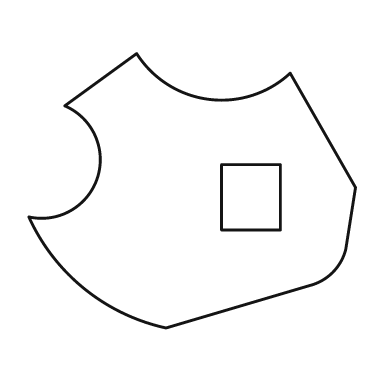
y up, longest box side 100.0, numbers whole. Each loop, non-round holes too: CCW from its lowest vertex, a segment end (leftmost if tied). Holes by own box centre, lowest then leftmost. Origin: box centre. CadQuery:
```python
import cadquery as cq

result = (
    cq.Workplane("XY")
    .moveTo(-8.0, -42.0)
    .lineTo(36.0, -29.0)
    .threePointArc((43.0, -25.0), (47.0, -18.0))
    .lineTo(50.0, 1.0)
    .lineTo(30.0, 36.0)
    .threePointArc((5.0, 28.0), (-17.0, 42.0))
    .lineTo(-39.0, 26.0)
    .threePointArc((-29.0, 4.0), (-50.0, -8.0))
    .threePointArc((-33.0, -30.0), (-8.0, -42.0))
    .close()
    .moveTo(9.0, -12.0)
    .lineTo(27.0, -12.0)
    .lineTo(27.0, 8.0)
    .lineTo(9.0, 8.0)
    .close()
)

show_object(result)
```